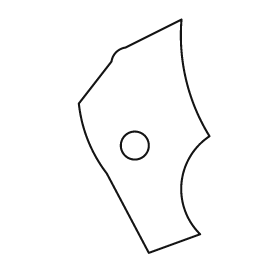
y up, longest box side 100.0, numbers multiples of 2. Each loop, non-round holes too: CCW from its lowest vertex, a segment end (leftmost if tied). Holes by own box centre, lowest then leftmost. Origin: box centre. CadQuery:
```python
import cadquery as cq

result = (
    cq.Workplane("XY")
    .moveTo(2.0, -50.0)
    .lineTo(24.0, -42.0)
    .threePointArc((16.0, -20.0), (28.0, 0.0))
    .threePointArc((18.0, 24.0), (16.0, 50.0))
    .lineTo(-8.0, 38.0)
    .threePointArc((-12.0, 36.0), (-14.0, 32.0))
    .lineTo(-28.0, 14.0)
    .threePointArc((-24.0, -2.0), (-16.0, -16.0))
    .close()
    .moveTo(-4.0, -4.0)
    .circle(6.0)
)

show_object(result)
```